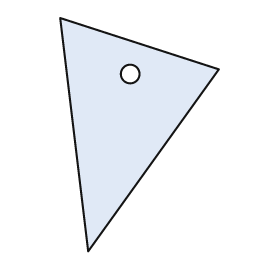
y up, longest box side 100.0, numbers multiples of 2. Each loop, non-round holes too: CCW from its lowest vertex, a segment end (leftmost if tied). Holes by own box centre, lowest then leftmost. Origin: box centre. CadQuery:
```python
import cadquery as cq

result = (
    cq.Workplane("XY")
    .moveTo(-22.0, -50.0)
    .lineTo(34.0, 28.0)
    .lineTo(-34.0, 50.0)
    .close()
    .moveTo(-4.0, 26.0)
    .circle(4.0)
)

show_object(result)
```